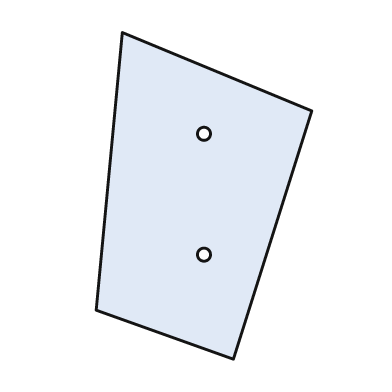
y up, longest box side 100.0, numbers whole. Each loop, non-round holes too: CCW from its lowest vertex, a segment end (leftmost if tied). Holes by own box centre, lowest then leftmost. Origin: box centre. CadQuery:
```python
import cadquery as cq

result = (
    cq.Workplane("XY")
    .moveTo(9.0, -50.0)
    .lineTo(33.0, 26.0)
    .lineTo(-25.0, 50.0)
    .lineTo(-33.0, -35.0)
    .close()
    .moveTo(0.0, -18.0)
    .circle(2.0)
    .moveTo(0.0, 19.0)
    .circle(2.0)
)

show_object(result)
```